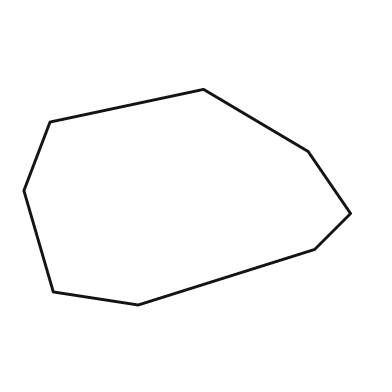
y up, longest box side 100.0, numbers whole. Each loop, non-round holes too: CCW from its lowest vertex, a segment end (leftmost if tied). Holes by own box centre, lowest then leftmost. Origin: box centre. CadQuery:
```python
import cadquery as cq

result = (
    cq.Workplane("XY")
    .moveTo(-15.0, -33.0)
    .lineTo(39.0, -16.0)
    .lineTo(50.0, -5.0)
    .lineTo(37.0, 14.0)
    .lineTo(5.0, 33.0)
    .lineTo(-42.0, 23.0)
    .lineTo(-50.0, 2.0)
    .lineTo(-41.0, -29.0)
    .close()
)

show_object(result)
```